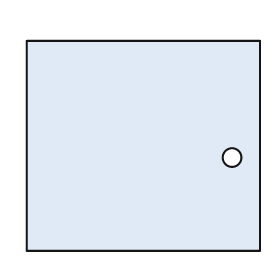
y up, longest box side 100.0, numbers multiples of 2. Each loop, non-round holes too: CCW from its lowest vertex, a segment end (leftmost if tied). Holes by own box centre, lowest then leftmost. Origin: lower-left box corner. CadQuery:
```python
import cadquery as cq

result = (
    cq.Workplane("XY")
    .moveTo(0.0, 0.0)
    .lineTo(100.0, 0.0)
    .lineTo(100.0, 90.0)
    .lineTo(0.0, 90.0)
    .close()
    .moveTo(88.0, 40.0)
    .circle(4.0)
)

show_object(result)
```